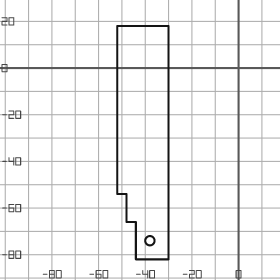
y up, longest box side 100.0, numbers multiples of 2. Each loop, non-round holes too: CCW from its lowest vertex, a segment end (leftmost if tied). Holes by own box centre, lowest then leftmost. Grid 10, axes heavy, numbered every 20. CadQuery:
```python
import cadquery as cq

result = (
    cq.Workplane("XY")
    .moveTo(-44.0, -82.0)
    .lineTo(-30.0, -82.0)
    .lineTo(-30.0, 18.0)
    .lineTo(-52.0, 18.0)
    .lineTo(-52.0, -54.0)
    .lineTo(-48.0, -54.0)
    .lineTo(-48.0, -66.0)
    .lineTo(-44.0, -66.0)
    .close()
    .moveTo(-38.0, -74.0)
    .circle(2.0)
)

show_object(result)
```